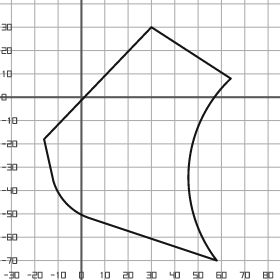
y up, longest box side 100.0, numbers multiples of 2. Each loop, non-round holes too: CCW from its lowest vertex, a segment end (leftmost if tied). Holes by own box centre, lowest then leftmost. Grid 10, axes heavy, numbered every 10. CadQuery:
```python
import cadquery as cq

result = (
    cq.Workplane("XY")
    .moveTo(58.0, -70.0)
    .threePointArc((46.0, -30.0), (64.0, 8.0))
    .lineTo(30.0, 30.0)
    .lineTo(-16.0, -18.0)
    .lineTo(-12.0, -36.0)
    .threePointArc((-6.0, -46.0), (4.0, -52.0))
    .close()
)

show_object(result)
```